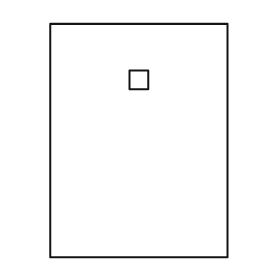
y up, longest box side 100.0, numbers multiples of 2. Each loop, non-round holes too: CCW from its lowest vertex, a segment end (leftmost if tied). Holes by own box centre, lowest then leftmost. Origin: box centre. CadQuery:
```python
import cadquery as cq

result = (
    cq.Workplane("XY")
    .moveTo(-38.0, -50.0)
    .lineTo(38.0, -50.0)
    .lineTo(38.0, 50.0)
    .lineTo(-38.0, 50.0)
    .close()
    .moveTo(-4.0, 22.0)
    .lineTo(4.0, 22.0)
    .lineTo(4.0, 30.0)
    .lineTo(-4.0, 30.0)
    .close()
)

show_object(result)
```